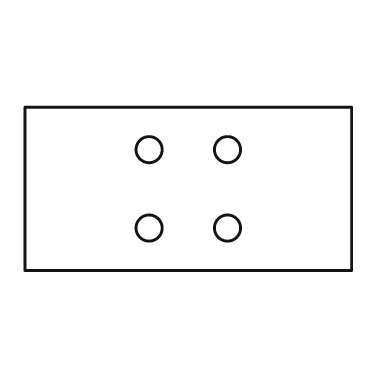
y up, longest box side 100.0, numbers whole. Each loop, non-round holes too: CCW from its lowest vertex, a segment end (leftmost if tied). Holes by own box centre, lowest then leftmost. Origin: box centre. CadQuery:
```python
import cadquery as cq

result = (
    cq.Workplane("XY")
    .moveTo(-50.0, -25.0)
    .lineTo(50.0, -25.0)
    .lineTo(50.0, 25.0)
    .lineTo(-50.0, 25.0)
    .close()
    .moveTo(-12.0, -12.0)
    .circle(4.0)
    .moveTo(12.0, -12.0)
    .circle(4.0)
    .moveTo(-12.0, 12.0)
    .circle(4.0)
    .moveTo(12.0, 12.0)
    .circle(4.0)
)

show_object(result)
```